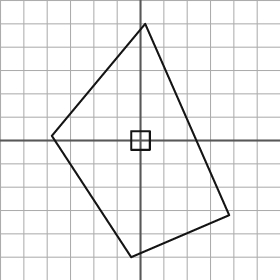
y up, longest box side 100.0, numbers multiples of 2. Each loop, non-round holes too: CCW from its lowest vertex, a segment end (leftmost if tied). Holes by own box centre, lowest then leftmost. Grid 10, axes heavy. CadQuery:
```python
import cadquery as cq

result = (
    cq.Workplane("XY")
    .moveTo(-4.0, -50.0)
    .lineTo(38.0, -32.0)
    .lineTo(2.0, 50.0)
    .lineTo(-38.0, 2.0)
    .close()
    .moveTo(-4.0, -4.0)
    .lineTo(4.0, -4.0)
    .lineTo(4.0, 4.0)
    .lineTo(-4.0, 4.0)
    .close()
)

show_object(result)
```